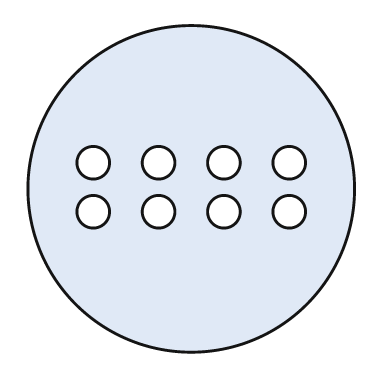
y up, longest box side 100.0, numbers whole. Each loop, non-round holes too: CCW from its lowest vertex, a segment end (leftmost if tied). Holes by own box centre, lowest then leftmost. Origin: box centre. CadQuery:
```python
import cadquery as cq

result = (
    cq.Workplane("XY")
    .moveTo(0.0, 0.0)
    .circle(50.0)
    .moveTo(-30.0, -7.0)
    .circle(5.0)
    .moveTo(-10.0, -7.0)
    .circle(5.0)
    .moveTo(10.0, -7.0)
    .circle(5.0)
    .moveTo(30.0, -7.0)
    .circle(5.0)
    .moveTo(-30.0, 8.0)
    .circle(5.0)
    .moveTo(-10.0, 8.0)
    .circle(5.0)
    .moveTo(10.0, 8.0)
    .circle(5.0)
    .moveTo(30.0, 8.0)
    .circle(5.0)
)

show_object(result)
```